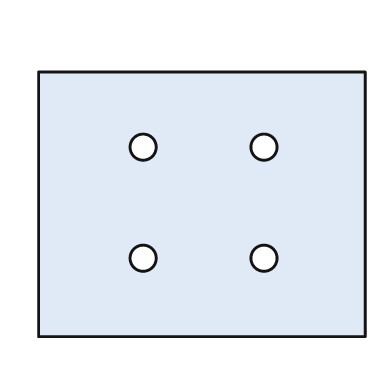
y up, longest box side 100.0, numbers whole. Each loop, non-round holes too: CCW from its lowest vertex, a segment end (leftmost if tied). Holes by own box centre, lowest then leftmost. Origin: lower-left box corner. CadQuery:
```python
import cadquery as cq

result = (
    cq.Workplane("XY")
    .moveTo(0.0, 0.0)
    .lineTo(100.0, 0.0)
    .lineTo(100.0, 81.0)
    .lineTo(0.0, 81.0)
    .close()
    .moveTo(32.0, 24.0)
    .circle(4.0)
    .moveTo(69.0, 24.0)
    .circle(4.0)
    .moveTo(32.0, 58.0)
    .circle(4.0)
    .moveTo(69.0, 58.0)
    .circle(4.0)
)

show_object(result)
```